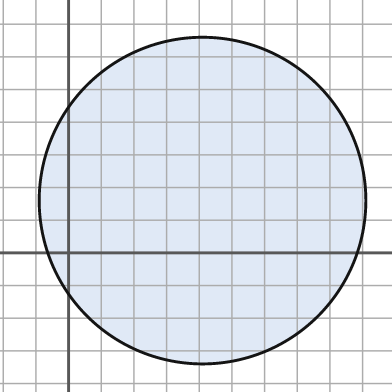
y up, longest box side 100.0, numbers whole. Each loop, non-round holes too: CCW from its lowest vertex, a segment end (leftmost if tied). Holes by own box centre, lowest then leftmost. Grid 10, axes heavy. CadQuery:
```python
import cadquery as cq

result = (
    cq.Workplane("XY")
    .moveTo(41.0, 16.0)
    .circle(50.0)
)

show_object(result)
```